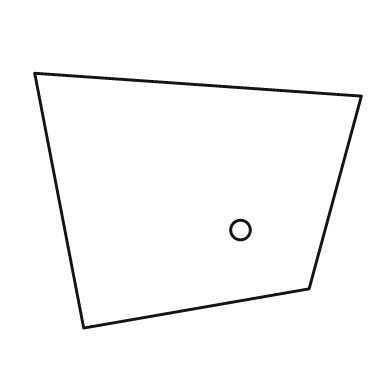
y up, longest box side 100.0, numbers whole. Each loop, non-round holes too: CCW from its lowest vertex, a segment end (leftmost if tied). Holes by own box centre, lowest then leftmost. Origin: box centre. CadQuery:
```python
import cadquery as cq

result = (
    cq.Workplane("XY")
    .moveTo(-35.0, -39.0)
    .lineTo(34.0, -27.0)
    .lineTo(50.0, 32.0)
    .lineTo(-50.0, 39.0)
    .close()
    .moveTo(13.0, -9.0)
    .circle(3.0)
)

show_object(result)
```